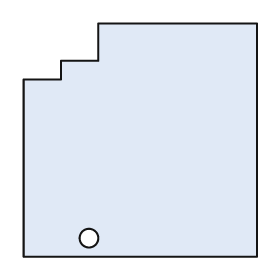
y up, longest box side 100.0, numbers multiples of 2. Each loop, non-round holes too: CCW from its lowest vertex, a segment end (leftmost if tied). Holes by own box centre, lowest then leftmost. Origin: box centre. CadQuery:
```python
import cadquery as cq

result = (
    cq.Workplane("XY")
    .moveTo(-50.0, -50.0)
    .lineTo(50.0, -50.0)
    .lineTo(50.0, 50.0)
    .lineTo(-18.0, 50.0)
    .lineTo(-18.0, 34.0)
    .lineTo(-34.0, 34.0)
    .lineTo(-34.0, 26.0)
    .lineTo(-50.0, 26.0)
    .close()
    .moveTo(-22.0, -42.0)
    .circle(4.0)
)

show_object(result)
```